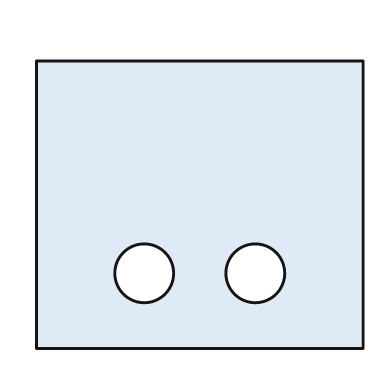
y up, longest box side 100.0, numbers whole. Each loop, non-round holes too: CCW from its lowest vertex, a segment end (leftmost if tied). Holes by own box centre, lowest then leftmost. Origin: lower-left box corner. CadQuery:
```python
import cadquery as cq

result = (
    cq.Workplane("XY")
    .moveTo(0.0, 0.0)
    .lineTo(100.0, 0.0)
    .lineTo(100.0, 88.0)
    .lineTo(0.0, 88.0)
    .close()
    .moveTo(33.0, 23.0)
    .circle(9.0)
    .moveTo(67.0, 23.0)
    .circle(9.0)
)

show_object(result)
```